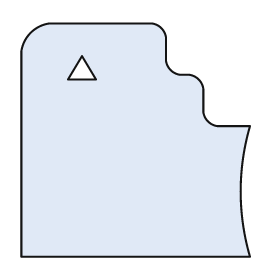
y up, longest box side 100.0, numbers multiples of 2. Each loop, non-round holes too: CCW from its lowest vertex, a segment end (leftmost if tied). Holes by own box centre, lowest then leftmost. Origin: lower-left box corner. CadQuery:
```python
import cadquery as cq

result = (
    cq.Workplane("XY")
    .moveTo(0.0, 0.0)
    .lineTo(98.0, 0.0)
    .threePointArc((94.0, 28.0), (98.0, 56.0))
    .lineTo(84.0, 56.0)
    .threePointArc((80.0, 58.0), (78.0, 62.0))
    .lineTo(78.0, 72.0)
    .threePointArc((76.0, 76.0), (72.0, 78.0))
    .lineTo(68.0, 78.0)
    .threePointArc((64.0, 80.0), (62.0, 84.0))
    .lineTo(62.0, 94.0)
    .threePointArc((60.0, 98.0), (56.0, 100.0))
    .lineTo(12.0, 100.0)
    .threePointArc((4.0, 96.0), (0.0, 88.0))
    .close()
    .moveTo(20.0, 76.0)
    .lineTo(32.0, 76.0)
    .lineTo(26.0, 86.0)
    .close()
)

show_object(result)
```